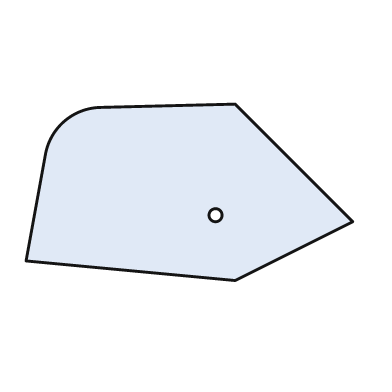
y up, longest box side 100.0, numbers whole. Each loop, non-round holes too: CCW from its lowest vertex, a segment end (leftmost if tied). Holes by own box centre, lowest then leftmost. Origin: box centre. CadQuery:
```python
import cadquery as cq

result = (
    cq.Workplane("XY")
    .moveTo(14.0, -27.0)
    .lineTo(50.0, -9.0)
    .lineTo(14.0, 27.0)
    .lineTo(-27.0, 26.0)
    .threePointArc((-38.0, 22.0), (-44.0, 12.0))
    .lineTo(-50.0, -21.0)
    .close()
    .moveTo(8.0, -7.0)
    .circle(2.0)
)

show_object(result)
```